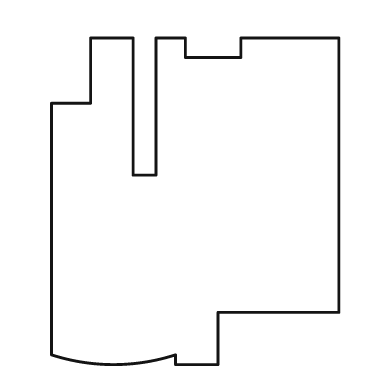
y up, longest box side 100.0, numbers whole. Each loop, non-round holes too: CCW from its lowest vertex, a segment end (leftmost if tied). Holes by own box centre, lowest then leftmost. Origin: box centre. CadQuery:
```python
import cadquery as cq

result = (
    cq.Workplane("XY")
    .moveTo(-6.0, -50.0)
    .lineTo(7.0, -50.0)
    .lineTo(7.0, -34.0)
    .lineTo(44.0, -34.0)
    .lineTo(44.0, 50.0)
    .lineTo(14.0, 50.0)
    .lineTo(14.0, 44.0)
    .lineTo(-3.0, 44.0)
    .lineTo(-3.0, 50.0)
    .lineTo(-12.0, 50.0)
    .lineTo(-12.0, 8.0)
    .lineTo(-19.0, 8.0)
    .lineTo(-19.0, 50.0)
    .lineTo(-32.0, 50.0)
    .lineTo(-32.0, 30.0)
    .lineTo(-44.0, 30.0)
    .lineTo(-44.0, -47.0)
    .threePointArc((-25.0, -50.0), (-6.0, -47.0))
    .close()
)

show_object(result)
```